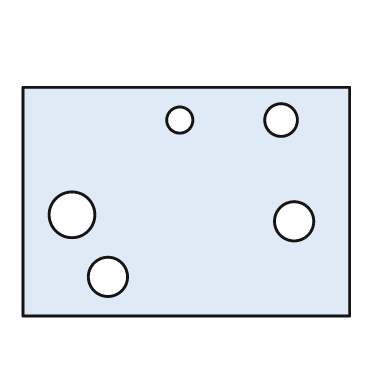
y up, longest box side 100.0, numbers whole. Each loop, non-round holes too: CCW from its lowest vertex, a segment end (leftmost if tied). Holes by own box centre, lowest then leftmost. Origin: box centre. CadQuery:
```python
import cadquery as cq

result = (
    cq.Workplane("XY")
    .moveTo(-50.0, -35.0)
    .lineTo(50.0, -35.0)
    .lineTo(50.0, 35.0)
    .lineTo(-50.0, 35.0)
    .close()
    .moveTo(-24.0, -23.0)
    .circle(6.0)
    .moveTo(33.0, -6.0)
    .circle(6.0)
    .moveTo(-35.0, -4.0)
    .circle(7.0)
    .moveTo(-2.0, 25.0)
    .circle(4.0)
    .moveTo(29.0, 25.0)
    .circle(5.0)
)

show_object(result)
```